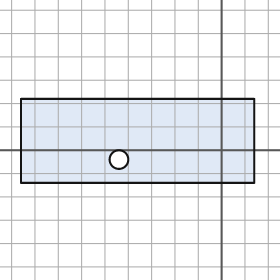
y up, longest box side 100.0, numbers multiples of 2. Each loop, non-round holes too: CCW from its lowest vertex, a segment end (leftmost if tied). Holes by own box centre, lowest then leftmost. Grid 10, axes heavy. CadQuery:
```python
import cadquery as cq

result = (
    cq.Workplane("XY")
    .moveTo(-86.0, -14.0)
    .lineTo(14.0, -14.0)
    .lineTo(14.0, 22.0)
    .lineTo(-86.0, 22.0)
    .close()
    .moveTo(-44.0, -4.0)
    .circle(4.0)
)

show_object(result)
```